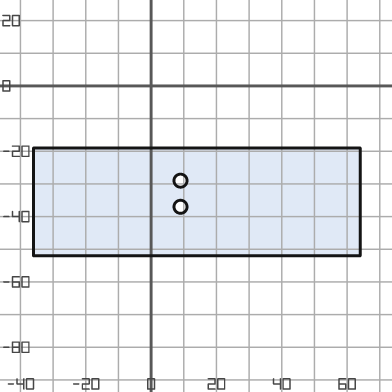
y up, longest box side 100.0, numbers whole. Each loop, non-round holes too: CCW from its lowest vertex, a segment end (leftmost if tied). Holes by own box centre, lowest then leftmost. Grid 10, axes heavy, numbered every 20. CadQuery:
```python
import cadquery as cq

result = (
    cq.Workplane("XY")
    .moveTo(-36.0, -52.0)
    .lineTo(64.0, -52.0)
    .lineTo(64.0, -19.0)
    .lineTo(-36.0, -19.0)
    .close()
    .moveTo(9.0, -37.0)
    .circle(2.0)
    .moveTo(9.0, -29.0)
    .circle(2.0)
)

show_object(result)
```